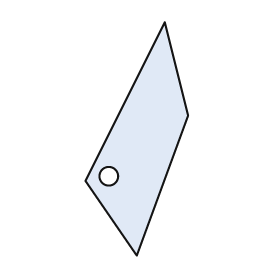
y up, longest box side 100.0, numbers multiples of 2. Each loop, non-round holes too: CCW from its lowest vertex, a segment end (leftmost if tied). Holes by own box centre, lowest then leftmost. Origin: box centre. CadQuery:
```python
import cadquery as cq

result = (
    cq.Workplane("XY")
    .moveTo(0.0, -50.0)
    .lineTo(22.0, 10.0)
    .lineTo(12.0, 50.0)
    .lineTo(-22.0, -18.0)
    .close()
    .moveTo(-12.0, -16.0)
    .circle(4.0)
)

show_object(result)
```